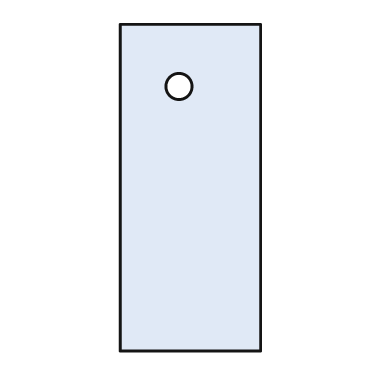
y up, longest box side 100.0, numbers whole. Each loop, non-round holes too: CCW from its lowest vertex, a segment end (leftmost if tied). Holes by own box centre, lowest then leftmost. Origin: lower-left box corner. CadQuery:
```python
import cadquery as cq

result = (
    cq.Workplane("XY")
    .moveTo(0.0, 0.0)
    .lineTo(43.0, 0.0)
    .lineTo(43.0, 100.0)
    .lineTo(0.0, 100.0)
    .close()
    .moveTo(18.0, 81.0)
    .circle(4.0)
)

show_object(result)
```